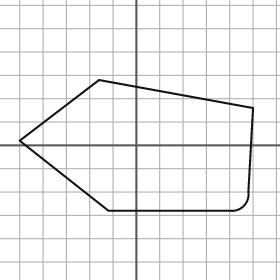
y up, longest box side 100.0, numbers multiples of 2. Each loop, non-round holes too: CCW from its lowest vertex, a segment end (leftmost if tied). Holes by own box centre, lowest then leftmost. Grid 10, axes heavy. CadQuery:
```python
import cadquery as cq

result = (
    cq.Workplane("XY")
    .moveTo(-12.0, -28.0)
    .lineTo(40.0, -28.0)
    .threePointArc((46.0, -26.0), (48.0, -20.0))
    .lineTo(50.0, 16.0)
    .lineTo(-16.0, 28.0)
    .lineTo(-50.0, 2.0)
    .close()
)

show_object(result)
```